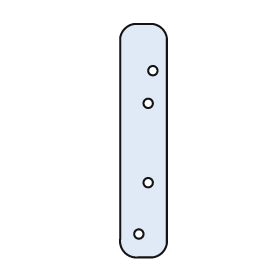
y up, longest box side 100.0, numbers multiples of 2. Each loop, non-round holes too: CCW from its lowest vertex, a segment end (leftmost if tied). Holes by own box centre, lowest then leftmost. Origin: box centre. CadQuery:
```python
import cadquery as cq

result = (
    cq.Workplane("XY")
    .moveTo(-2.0, -50.0)
    .lineTo(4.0, -50.0)
    .threePointArc((8.0, -48.0), (10.0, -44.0))
    .lineTo(10.0, 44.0)
    .threePointArc((8.0, 48.0), (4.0, 50.0))
    .lineTo(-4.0, 50.0)
    .threePointArc((-8.0, 48.0), (-10.0, 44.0))
    .lineTo(-10.0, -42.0)
    .threePointArc((-8.0, -48.0), (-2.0, -50.0))
    .close()
    .moveTo(-2.0, -40.0)
    .circle(2.0)
    .moveTo(2.0, -18.0)
    .circle(2.0)
    .moveTo(2.0, 16.0)
    .circle(2.0)
    .moveTo(4.0, 30.0)
    .circle(2.0)
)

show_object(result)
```